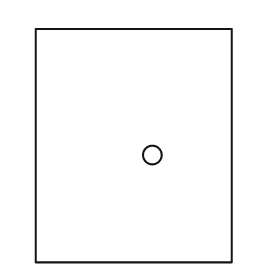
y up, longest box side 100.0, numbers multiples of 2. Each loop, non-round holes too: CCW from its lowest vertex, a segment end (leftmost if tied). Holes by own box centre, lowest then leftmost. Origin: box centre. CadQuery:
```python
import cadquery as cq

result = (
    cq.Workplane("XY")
    .moveTo(-42.0, -50.0)
    .lineTo(42.0, -50.0)
    .lineTo(42.0, 50.0)
    .lineTo(-42.0, 50.0)
    .close()
    .moveTo(8.0, -4.0)
    .circle(4.0)
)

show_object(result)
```